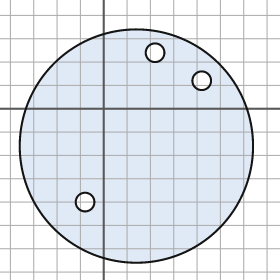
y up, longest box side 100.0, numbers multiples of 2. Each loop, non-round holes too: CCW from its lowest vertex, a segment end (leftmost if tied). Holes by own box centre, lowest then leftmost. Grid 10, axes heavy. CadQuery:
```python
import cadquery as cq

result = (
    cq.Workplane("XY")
    .moveTo(14.0, -16.0)
    .circle(50.0)
    .moveTo(-8.0, -40.0)
    .circle(4.0)
    .moveTo(42.0, 12.0)
    .circle(4.0)
    .moveTo(22.0, 24.0)
    .circle(4.0)
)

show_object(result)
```